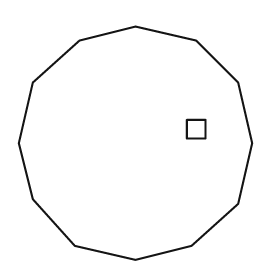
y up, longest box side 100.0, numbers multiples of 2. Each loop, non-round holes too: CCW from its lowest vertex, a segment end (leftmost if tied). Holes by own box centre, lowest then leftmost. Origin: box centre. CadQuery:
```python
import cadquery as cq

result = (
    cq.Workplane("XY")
    .moveTo(0.0, -50.0)
    .lineTo(24.0, -44.0)
    .lineTo(44.0, -26.0)
    .lineTo(50.0, 0.0)
    .lineTo(44.0, 26.0)
    .lineTo(26.0, 44.0)
    .lineTo(0.0, 50.0)
    .lineTo(-24.0, 44.0)
    .lineTo(-44.0, 26.0)
    .lineTo(-50.0, 0.0)
    .lineTo(-44.0, -24.0)
    .lineTo(-26.0, -44.0)
    .close()
    .moveTo(22.0, 2.0)
    .lineTo(30.0, 2.0)
    .lineTo(30.0, 10.0)
    .lineTo(22.0, 10.0)
    .close()
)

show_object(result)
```